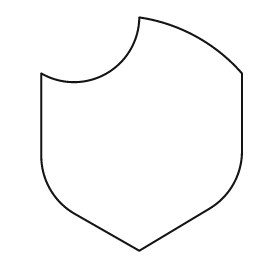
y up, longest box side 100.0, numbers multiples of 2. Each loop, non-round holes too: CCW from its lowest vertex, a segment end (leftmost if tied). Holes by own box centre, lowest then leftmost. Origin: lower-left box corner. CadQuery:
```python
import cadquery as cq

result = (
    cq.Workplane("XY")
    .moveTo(42.0, 0.0)
    .lineTo(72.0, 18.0)
    .threePointArc((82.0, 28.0), (86.0, 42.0))
    .lineTo(86.0, 76.0)
    .threePointArc((66.0, 92.0), (42.0, 100.0))
    .threePointArc((28.0, 76.0), (0.0, 76.0))
    .lineTo(0.0, 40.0)
    .threePointArc((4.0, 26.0), (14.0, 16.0))
    .close()
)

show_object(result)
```